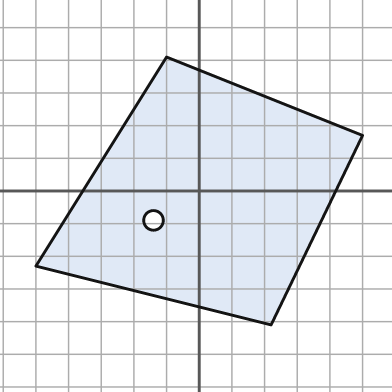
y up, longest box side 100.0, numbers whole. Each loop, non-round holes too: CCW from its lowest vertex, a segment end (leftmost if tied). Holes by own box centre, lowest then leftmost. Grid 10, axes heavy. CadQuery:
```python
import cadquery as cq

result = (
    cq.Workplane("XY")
    .moveTo(22.0, -41.0)
    .lineTo(50.0, 17.0)
    .lineTo(-10.0, 41.0)
    .lineTo(-50.0, -23.0)
    .close()
    .moveTo(-14.0, -9.0)
    .circle(3.0)
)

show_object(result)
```